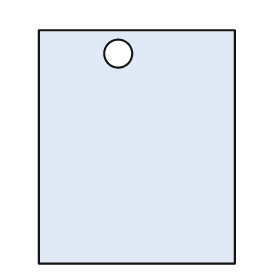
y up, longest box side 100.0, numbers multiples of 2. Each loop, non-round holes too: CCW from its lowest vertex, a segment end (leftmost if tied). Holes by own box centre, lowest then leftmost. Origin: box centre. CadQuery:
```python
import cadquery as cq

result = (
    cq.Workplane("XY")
    .moveTo(-42.0, -50.0)
    .lineTo(42.0, -50.0)
    .lineTo(42.0, 50.0)
    .lineTo(-42.0, 50.0)
    .close()
    .moveTo(-8.0, 40.0)
    .circle(6.0)
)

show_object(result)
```